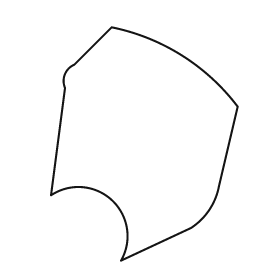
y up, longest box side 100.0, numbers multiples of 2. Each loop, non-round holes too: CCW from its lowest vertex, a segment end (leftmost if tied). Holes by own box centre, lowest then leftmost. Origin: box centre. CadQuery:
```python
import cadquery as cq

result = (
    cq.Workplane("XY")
    .moveTo(-10.0, -50.0)
    .lineTo(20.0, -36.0)
    .threePointArc((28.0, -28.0), (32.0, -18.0))
    .lineTo(40.0, 16.0)
    .threePointArc((16.0, 38.0), (-14.0, 50.0))
    .lineTo(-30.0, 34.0)
    .threePointArc((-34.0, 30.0), (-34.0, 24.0))
    .lineTo(-40.0, -22.0)
    .threePointArc((-14.0, -24.0), (-10.0, -50.0))
    .close()
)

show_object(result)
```